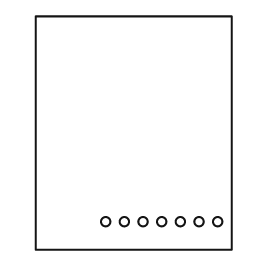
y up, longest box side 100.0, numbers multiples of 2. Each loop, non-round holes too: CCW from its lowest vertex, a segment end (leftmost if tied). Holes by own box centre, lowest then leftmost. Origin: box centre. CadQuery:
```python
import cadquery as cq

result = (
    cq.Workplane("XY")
    .moveTo(-42.0, -50.0)
    .lineTo(42.0, -50.0)
    .lineTo(42.0, 50.0)
    .lineTo(-42.0, 50.0)
    .close()
    .moveTo(-12.0, -38.0)
    .circle(2.0)
    .moveTo(-4.0, -38.0)
    .circle(2.0)
    .moveTo(4.0, -38.0)
    .circle(2.0)
    .moveTo(12.0, -38.0)
    .circle(2.0)
    .moveTo(20.0, -38.0)
    .circle(2.0)
    .moveTo(28.0, -38.0)
    .circle(2.0)
    .moveTo(36.0, -38.0)
    .circle(2.0)
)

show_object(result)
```